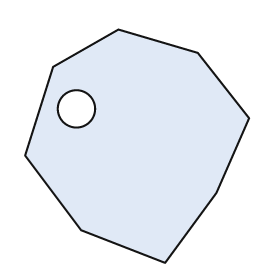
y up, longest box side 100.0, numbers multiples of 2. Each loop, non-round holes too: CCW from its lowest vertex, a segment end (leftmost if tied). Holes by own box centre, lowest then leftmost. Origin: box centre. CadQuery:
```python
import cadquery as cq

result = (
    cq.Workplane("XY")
    .moveTo(12.0, -50.0)
    .lineTo(34.0, -20.0)
    .lineTo(48.0, 12.0)
    .lineTo(26.0, 40.0)
    .lineTo(-8.0, 50.0)
    .lineTo(-36.0, 34.0)
    .lineTo(-48.0, -4.0)
    .lineTo(-24.0, -36.0)
    .close()
    .moveTo(-26.0, 16.0)
    .circle(8.0)
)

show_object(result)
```